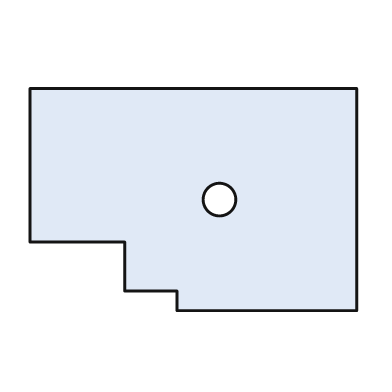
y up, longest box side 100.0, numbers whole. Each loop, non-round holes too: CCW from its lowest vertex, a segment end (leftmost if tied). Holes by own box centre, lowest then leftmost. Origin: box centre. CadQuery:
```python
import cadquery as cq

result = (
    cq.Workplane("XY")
    .moveTo(-5.0, -34.0)
    .lineTo(50.0, -34.0)
    .lineTo(50.0, 34.0)
    .lineTo(-50.0, 34.0)
    .lineTo(-50.0, -13.0)
    .lineTo(-21.0, -13.0)
    .lineTo(-21.0, -28.0)
    .lineTo(-5.0, -28.0)
    .close()
    .moveTo(8.0, 0.0)
    .circle(5.0)
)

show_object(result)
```